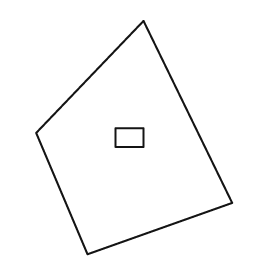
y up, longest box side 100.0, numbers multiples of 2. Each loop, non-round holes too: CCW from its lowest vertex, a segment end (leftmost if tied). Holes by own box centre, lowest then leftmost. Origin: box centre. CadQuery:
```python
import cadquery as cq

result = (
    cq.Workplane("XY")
    .moveTo(-20.0, -50.0)
    .lineTo(42.0, -28.0)
    .lineTo(4.0, 50.0)
    .lineTo(-42.0, 2.0)
    .close()
    .moveTo(-8.0, -4.0)
    .lineTo(4.0, -4.0)
    .lineTo(4.0, 4.0)
    .lineTo(-8.0, 4.0)
    .close()
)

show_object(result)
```